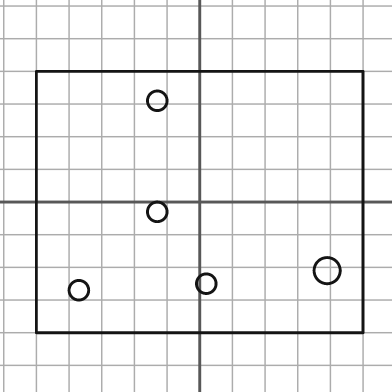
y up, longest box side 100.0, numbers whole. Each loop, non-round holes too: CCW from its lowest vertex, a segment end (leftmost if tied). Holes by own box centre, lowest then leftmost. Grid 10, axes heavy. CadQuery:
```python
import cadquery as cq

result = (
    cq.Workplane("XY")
    .moveTo(-50.0, -40.0)
    .lineTo(50.0, -40.0)
    .lineTo(50.0, 40.0)
    .lineTo(-50.0, 40.0)
    .close()
    .moveTo(-37.0, -27.0)
    .circle(3.0)
    .moveTo(2.0, -25.0)
    .circle(3.0)
    .moveTo(39.0, -21.0)
    .circle(4.0)
    .moveTo(-13.0, -3.0)
    .circle(3.0)
    .moveTo(-13.0, 31.0)
    .circle(3.0)
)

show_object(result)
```